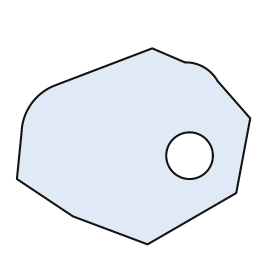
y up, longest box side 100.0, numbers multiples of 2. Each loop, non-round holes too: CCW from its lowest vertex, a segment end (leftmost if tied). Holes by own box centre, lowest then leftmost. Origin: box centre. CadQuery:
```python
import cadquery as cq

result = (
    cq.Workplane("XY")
    .moveTo(6.0, -42.0)
    .lineTo(44.0, -20.0)
    .lineTo(50.0, 12.0)
    .lineTo(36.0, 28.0)
    .threePointArc((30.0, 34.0), (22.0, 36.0))
    .lineTo(8.0, 42.0)
    .lineTo(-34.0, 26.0)
    .threePointArc((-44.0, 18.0), (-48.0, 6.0))
    .lineTo(-50.0, -14.0)
    .lineTo(-26.0, -30.0)
    .close()
    .moveTo(24.0, -4.0)
    .circle(10.0)
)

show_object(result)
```